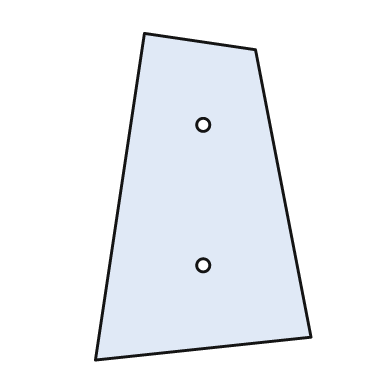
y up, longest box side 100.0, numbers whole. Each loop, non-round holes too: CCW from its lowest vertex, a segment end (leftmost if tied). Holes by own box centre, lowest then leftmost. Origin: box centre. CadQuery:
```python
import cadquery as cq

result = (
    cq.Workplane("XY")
    .moveTo(-33.0, -50.0)
    .lineTo(33.0, -43.0)
    .lineTo(16.0, 45.0)
    .lineTo(-18.0, 50.0)
    .close()
    .moveTo(0.0, -21.0)
    .circle(2.0)
    .moveTo(0.0, 22.0)
    .circle(2.0)
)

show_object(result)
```